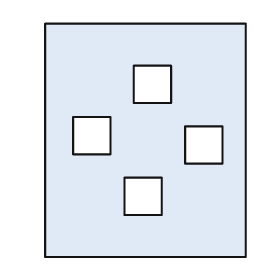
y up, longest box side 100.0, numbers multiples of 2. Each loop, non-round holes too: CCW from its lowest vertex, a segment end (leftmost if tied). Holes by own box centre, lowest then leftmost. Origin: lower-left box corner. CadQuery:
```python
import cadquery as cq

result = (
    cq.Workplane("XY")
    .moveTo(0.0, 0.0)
    .lineTo(86.0, 0.0)
    .lineTo(86.0, 100.0)
    .lineTo(0.0, 100.0)
    .close()
    .moveTo(34.0, 18.0)
    .lineTo(50.0, 18.0)
    .lineTo(50.0, 34.0)
    .lineTo(34.0, 34.0)
    .close()
    .moveTo(60.0, 40.0)
    .lineTo(76.0, 40.0)
    .lineTo(76.0, 56.0)
    .lineTo(60.0, 56.0)
    .close()
    .moveTo(12.0, 44.0)
    .lineTo(28.0, 44.0)
    .lineTo(28.0, 60.0)
    .lineTo(12.0, 60.0)
    .close()
    .moveTo(38.0, 66.0)
    .lineTo(54.0, 66.0)
    .lineTo(54.0, 82.0)
    .lineTo(38.0, 82.0)
    .close()
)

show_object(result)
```